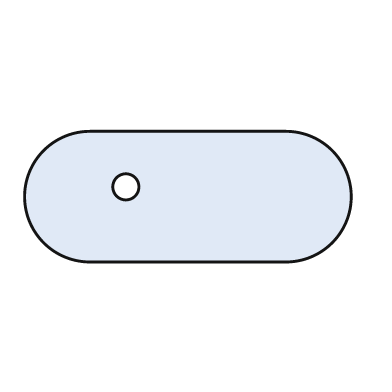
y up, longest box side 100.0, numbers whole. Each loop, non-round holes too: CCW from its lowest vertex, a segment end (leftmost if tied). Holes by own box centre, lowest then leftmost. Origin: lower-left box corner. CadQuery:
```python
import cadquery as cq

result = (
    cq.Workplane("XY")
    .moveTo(20.0, 0.0)
    .lineTo(80.0, 0.0)
    .threePointArc((100.0, 20.0), (80.0, 40.0))
    .lineTo(20.0, 40.0)
    .threePointArc((0.0, 20.0), (20.0, 0.0))
    .close()
    .moveTo(31.0, 23.0)
    .circle(4.0)
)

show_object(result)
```